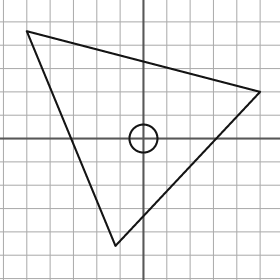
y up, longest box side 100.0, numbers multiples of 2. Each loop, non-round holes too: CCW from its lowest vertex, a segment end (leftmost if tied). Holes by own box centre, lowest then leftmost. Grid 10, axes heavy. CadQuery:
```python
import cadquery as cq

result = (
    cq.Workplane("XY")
    .moveTo(-12.0, -46.0)
    .lineTo(50.0, 20.0)
    .lineTo(-50.0, 46.0)
    .close()
    .moveTo(0.0, 0.0)
    .circle(6.0)
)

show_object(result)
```